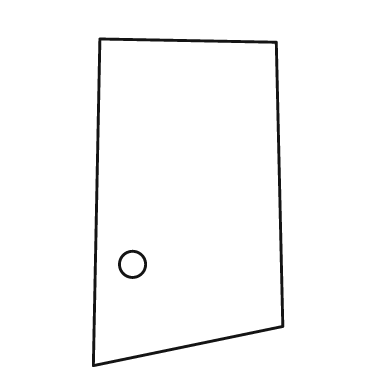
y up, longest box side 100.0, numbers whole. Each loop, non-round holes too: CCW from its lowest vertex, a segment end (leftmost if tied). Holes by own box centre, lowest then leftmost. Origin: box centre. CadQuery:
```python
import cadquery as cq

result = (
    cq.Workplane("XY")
    .moveTo(-29.0, -50.0)
    .lineTo(29.0, -38.0)
    .lineTo(27.0, 49.0)
    .lineTo(-27.0, 50.0)
    .close()
    .moveTo(-17.0, -19.0)
    .circle(4.0)
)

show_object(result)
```